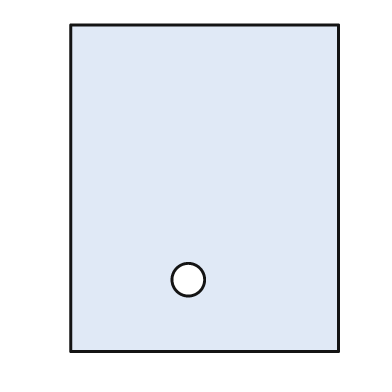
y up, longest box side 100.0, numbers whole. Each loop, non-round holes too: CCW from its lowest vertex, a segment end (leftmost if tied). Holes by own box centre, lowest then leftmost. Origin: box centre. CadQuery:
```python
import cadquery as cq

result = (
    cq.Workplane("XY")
    .moveTo(-41.0, -50.0)
    .lineTo(41.0, -50.0)
    .lineTo(41.0, 50.0)
    .lineTo(-41.0, 50.0)
    .close()
    .moveTo(-5.0, -28.0)
    .circle(5.0)
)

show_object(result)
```